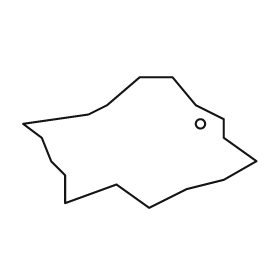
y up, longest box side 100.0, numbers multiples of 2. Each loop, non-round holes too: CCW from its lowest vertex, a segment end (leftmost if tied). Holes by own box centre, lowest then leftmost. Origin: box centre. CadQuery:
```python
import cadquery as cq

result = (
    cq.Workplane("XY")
    .moveTo(4.0, -28.0)
    .lineTo(20.0, -20.0)
    .lineTo(36.0, -16.0)
    .lineTo(50.0, -8.0)
    .lineTo(36.0, 2.0)
    .lineTo(36.0, 10.0)
    .lineTo(24.0, 16.0)
    .lineTo(14.0, 28.0)
    .lineTo(0.0, 28.0)
    .lineTo(-14.0, 16.0)
    .lineTo(-22.0, 12.0)
    .lineTo(-50.0, 8.0)
    .lineTo(-42.0, 2.0)
    .lineTo(-38.0, -8.0)
    .lineTo(-32.0, -14.0)
    .lineTo(-32.0, -26.0)
    .lineTo(-10.0, -18.0)
    .close()
    .moveTo(26.0, 8.0)
    .circle(2.0)
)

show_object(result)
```